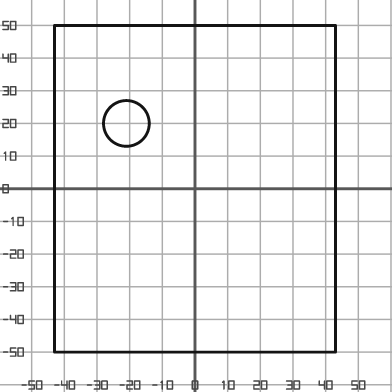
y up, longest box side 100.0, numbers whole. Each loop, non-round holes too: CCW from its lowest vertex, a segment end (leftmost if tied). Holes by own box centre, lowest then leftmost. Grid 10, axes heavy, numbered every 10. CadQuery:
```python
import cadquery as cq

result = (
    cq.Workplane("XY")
    .moveTo(-43.0, -50.0)
    .lineTo(43.0, -50.0)
    .lineTo(43.0, 50.0)
    .lineTo(-43.0, 50.0)
    .close()
    .moveTo(-21.0, 20.0)
    .circle(7.0)
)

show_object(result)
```